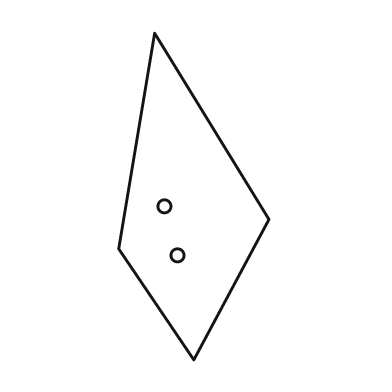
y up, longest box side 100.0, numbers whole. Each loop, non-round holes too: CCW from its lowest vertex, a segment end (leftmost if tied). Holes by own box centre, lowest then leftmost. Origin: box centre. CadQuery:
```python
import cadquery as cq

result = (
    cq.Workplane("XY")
    .moveTo(0.0, -50.0)
    .lineTo(23.0, -7.0)
    .lineTo(-12.0, 50.0)
    .lineTo(-23.0, -16.0)
    .close()
    .moveTo(-5.0, -18.0)
    .circle(2.0)
    .moveTo(-9.0, -3.0)
    .circle(2.0)
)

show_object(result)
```